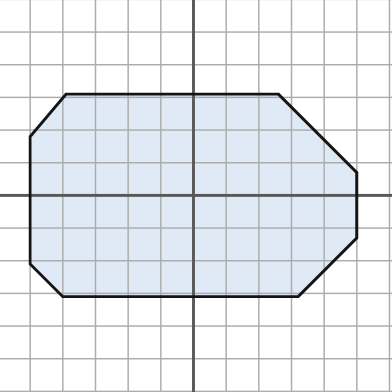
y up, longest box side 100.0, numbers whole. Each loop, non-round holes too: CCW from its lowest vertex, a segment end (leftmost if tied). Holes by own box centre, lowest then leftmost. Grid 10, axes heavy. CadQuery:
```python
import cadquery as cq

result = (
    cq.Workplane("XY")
    .moveTo(-40.0, -31.0)
    .lineTo(32.0, -31.0)
    .lineTo(50.0, -13.0)
    .lineTo(50.0, 7.0)
    .lineTo(26.0, 31.0)
    .lineTo(-39.0, 31.0)
    .lineTo(-50.0, 18.0)
    .lineTo(-50.0, -21.0)
    .close()
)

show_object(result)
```